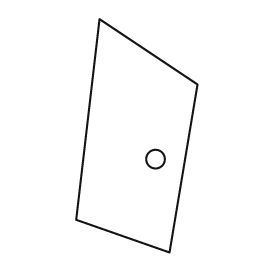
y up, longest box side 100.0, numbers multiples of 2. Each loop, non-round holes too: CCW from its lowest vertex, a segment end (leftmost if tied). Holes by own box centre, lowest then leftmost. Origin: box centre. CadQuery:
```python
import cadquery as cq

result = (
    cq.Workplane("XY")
    .moveTo(14.0, -50.0)
    .lineTo(26.0, 22.0)
    .lineTo(-16.0, 50.0)
    .lineTo(-26.0, -36.0)
    .close()
    .moveTo(8.0, -10.0)
    .circle(4.0)
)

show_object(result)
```